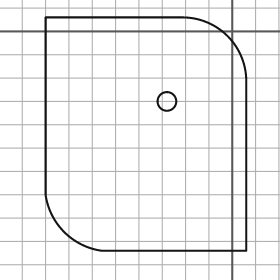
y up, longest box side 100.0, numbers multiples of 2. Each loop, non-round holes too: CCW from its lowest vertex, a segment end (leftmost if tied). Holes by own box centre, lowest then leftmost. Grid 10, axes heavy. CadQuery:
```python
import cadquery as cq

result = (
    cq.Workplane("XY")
    .moveTo(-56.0, -94.0)
    .lineTo(6.0, -94.0)
    .lineTo(6.0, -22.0)
    .threePointArc((-2.0, -2.0), (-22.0, 6.0))
    .lineTo(-80.0, 6.0)
    .lineTo(-80.0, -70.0)
    .threePointArc((-72.0, -86.0), (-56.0, -94.0))
    .close()
    .moveTo(-28.0, -30.0)
    .circle(4.0)
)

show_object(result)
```